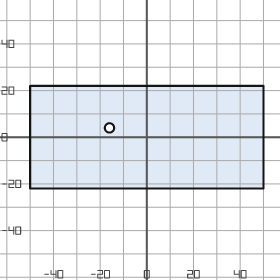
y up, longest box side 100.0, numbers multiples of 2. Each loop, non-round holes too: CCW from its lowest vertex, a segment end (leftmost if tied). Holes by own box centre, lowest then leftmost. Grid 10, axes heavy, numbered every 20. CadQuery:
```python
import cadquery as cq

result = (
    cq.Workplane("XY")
    .moveTo(-50.0, -22.0)
    .lineTo(50.0, -22.0)
    .lineTo(50.0, 22.0)
    .lineTo(-50.0, 22.0)
    .close()
    .moveTo(-16.0, 4.0)
    .circle(2.0)
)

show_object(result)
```